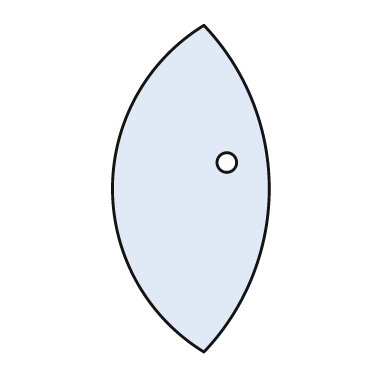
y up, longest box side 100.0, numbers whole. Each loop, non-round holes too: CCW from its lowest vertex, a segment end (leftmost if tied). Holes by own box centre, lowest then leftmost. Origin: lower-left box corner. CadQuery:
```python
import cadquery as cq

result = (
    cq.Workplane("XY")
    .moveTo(28.0, 0.0)
    .threePointArc((48.0, 50.0), (28.0, 100.0))
    .threePointArc((0.0, 50.0), (28.0, 0.0))
    .close()
    .moveTo(35.0, 58.0)
    .circle(3.0)
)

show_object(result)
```